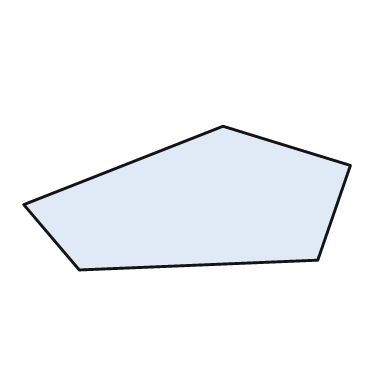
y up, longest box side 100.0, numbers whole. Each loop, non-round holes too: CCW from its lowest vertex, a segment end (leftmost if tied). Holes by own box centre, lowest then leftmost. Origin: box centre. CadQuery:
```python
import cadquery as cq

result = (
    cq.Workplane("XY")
    .moveTo(-33.0, -22.0)
    .lineTo(40.0, -19.0)
    .lineTo(50.0, 10.0)
    .lineTo(11.0, 22.0)
    .lineTo(-50.0, -2.0)
    .close()
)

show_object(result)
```